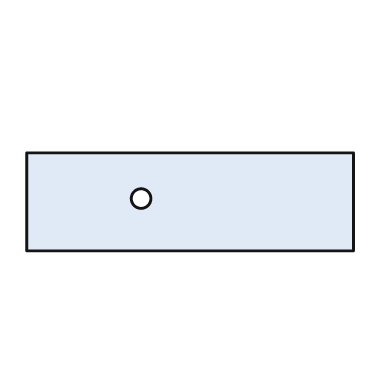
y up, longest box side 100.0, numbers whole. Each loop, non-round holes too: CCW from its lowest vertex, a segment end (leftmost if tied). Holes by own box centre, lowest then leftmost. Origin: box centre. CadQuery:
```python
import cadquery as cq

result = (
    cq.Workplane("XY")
    .moveTo(-50.0, -15.0)
    .lineTo(50.0, -15.0)
    .lineTo(50.0, 15.0)
    .lineTo(-50.0, 15.0)
    .close()
    .moveTo(-15.0, 1.0)
    .circle(3.0)
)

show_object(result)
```